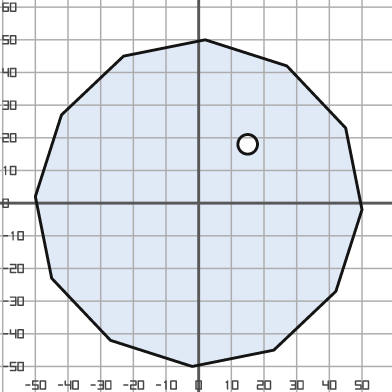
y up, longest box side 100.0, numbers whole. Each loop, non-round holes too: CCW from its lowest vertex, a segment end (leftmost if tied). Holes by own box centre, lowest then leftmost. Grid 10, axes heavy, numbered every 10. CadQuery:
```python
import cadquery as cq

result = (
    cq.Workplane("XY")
    .moveTo(-2.0, -50.0)
    .lineTo(23.0, -45.0)
    .lineTo(42.0, -27.0)
    .lineTo(50.0, -2.0)
    .lineTo(45.0, 23.0)
    .lineTo(27.0, 42.0)
    .lineTo(2.0, 50.0)
    .lineTo(-23.0, 45.0)
    .lineTo(-42.0, 27.0)
    .lineTo(-50.0, 2.0)
    .lineTo(-45.0, -23.0)
    .lineTo(-27.0, -42.0)
    .close()
    .moveTo(15.0, 18.0)
    .circle(3.0)
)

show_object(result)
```